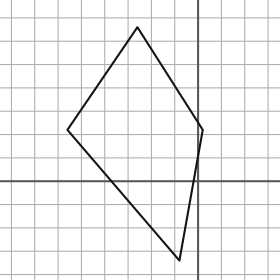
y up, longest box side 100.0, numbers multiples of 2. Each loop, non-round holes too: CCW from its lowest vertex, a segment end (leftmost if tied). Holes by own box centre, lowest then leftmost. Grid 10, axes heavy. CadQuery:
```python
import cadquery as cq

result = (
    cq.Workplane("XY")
    .moveTo(-8.0, -34.0)
    .lineTo(2.0, 22.0)
    .lineTo(-26.0, 66.0)
    .lineTo(-56.0, 22.0)
    .close()
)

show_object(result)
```